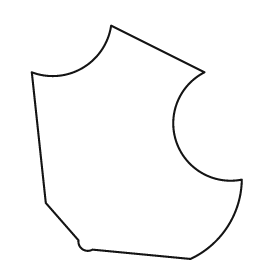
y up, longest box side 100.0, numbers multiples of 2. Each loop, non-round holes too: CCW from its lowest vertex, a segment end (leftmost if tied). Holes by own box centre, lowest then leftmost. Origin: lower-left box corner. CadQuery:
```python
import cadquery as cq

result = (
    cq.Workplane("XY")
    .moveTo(68.0, 0.0)
    .threePointArc((84.0, 14.0), (90.0, 34.0))
    .threePointArc((62.0, 50.0), (74.0, 80.0))
    .lineTo(34.0, 100.0)
    .threePointArc((22.0, 82.0), (0.0, 80.0))
    .lineTo(6.0, 24.0)
    .lineTo(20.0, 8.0)
    .threePointArc((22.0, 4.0), (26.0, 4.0))
    .close()
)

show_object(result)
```